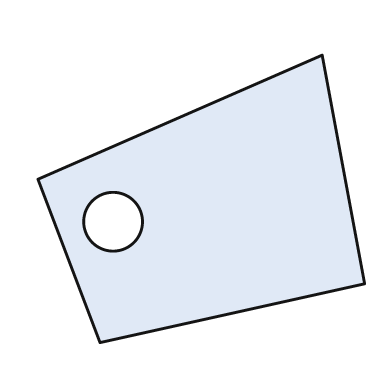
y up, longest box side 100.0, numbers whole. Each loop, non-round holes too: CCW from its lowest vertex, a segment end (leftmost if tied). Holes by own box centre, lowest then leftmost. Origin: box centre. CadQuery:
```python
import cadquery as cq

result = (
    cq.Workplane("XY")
    .moveTo(-31.0, -44.0)
    .lineTo(50.0, -26.0)
    .lineTo(37.0, 44.0)
    .lineTo(-50.0, 6.0)
    .close()
    .moveTo(-27.0, -7.0)
    .circle(9.0)
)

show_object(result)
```